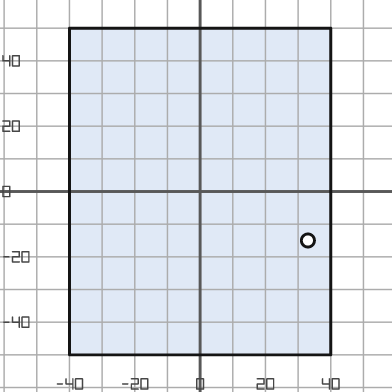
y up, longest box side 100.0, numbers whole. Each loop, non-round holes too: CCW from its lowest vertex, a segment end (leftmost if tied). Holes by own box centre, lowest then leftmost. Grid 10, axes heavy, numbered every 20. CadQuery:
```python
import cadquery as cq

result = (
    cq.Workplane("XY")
    .moveTo(-40.0, -50.0)
    .lineTo(40.0, -50.0)
    .lineTo(40.0, 50.0)
    .lineTo(-40.0, 50.0)
    .close()
    .moveTo(33.0, -15.0)
    .circle(2.0)
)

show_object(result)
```